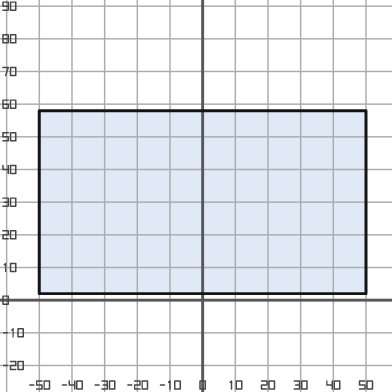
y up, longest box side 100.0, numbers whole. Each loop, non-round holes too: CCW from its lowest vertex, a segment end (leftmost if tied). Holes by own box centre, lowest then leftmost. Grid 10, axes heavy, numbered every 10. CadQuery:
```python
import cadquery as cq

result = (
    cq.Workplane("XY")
    .moveTo(-50.0, 2.0)
    .lineTo(50.0, 2.0)
    .lineTo(50.0, 58.0)
    .lineTo(-50.0, 58.0)
    .close()
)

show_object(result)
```